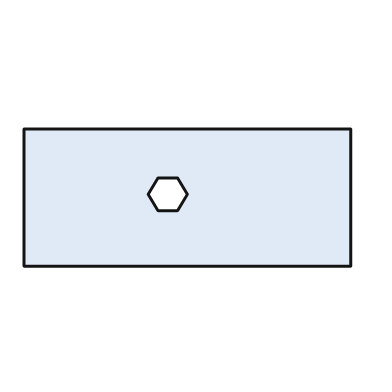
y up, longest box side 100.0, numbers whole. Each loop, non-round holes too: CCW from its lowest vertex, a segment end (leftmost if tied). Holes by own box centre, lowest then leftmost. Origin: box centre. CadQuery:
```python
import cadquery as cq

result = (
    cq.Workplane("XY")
    .moveTo(-50.0, -21.0)
    .lineTo(50.0, -21.0)
    .lineTo(50.0, 21.0)
    .lineTo(-50.0, 21.0)
    .close()
    .moveTo(-9.0, -4.0)
    .lineTo(-3.0, -4.0)
    .lineTo(0.0, 1.0)
    .lineTo(-3.0, 6.0)
    .lineTo(-9.0, 6.0)
    .lineTo(-12.0, 1.0)
    .close()
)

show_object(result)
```